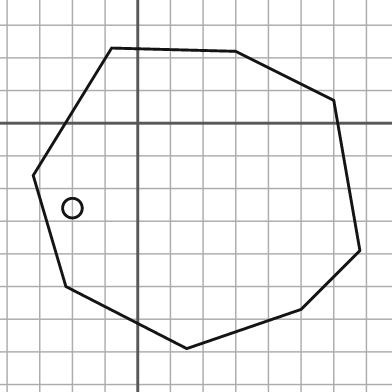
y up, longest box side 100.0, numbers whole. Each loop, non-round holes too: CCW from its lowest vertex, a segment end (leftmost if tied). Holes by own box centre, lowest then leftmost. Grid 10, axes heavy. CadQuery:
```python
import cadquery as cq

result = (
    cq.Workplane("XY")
    .moveTo(15.0, -69.0)
    .lineTo(50.0, -57.0)
    .lineTo(68.0, -39.0)
    .lineTo(60.0, 7.0)
    .lineTo(30.0, 22.0)
    .lineTo(-8.0, 23.0)
    .lineTo(-32.0, -16.0)
    .lineTo(-22.0, -50.0)
    .close()
    .moveTo(-20.0, -26.0)
    .circle(3.0)
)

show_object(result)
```